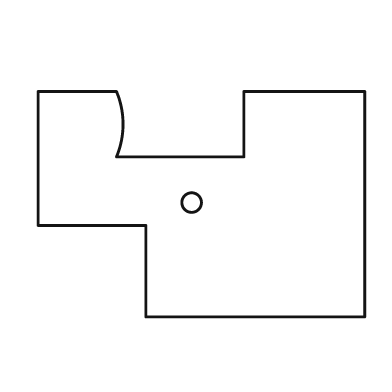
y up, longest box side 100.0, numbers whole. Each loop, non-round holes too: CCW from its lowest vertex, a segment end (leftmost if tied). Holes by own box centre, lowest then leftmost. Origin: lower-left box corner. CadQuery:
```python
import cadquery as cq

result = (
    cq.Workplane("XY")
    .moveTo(33.0, 0.0)
    .lineTo(100.0, 0.0)
    .lineTo(100.0, 69.0)
    .lineTo(63.0, 69.0)
    .lineTo(63.0, 49.0)
    .lineTo(24.0, 49.0)
    .threePointArc((26.0, 59.0), (24.0, 69.0))
    .lineTo(0.0, 69.0)
    .lineTo(0.0, 28.0)
    .lineTo(33.0, 28.0)
    .close()
    .moveTo(47.0, 35.0)
    .circle(3.0)
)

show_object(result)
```